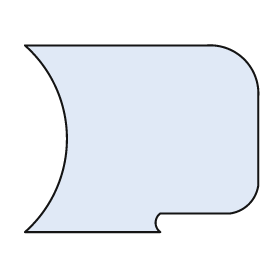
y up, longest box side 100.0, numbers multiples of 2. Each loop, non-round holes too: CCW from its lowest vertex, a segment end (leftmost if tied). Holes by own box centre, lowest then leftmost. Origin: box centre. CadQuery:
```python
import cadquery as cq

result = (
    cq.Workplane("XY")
    .moveTo(-50.0, -40.0)
    .lineTo(8.0, -40.0)
    .threePointArc((6.0, -36.0), (8.0, -32.0))
    .lineTo(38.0, -32.0)
    .threePointArc((46.0, -28.0), (50.0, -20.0))
    .lineTo(50.0, 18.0)
    .threePointArc((44.0, 34.0), (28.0, 40.0))
    .lineTo(-50.0, 40.0)
    .threePointArc((-32.0, 0.0), (-50.0, -40.0))
    .close()
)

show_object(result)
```